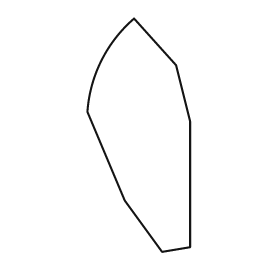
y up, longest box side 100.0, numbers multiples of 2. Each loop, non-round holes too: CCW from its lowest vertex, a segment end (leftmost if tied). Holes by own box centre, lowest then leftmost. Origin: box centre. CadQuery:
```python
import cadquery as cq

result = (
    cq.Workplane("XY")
    .moveTo(10.0, -50.0)
    .lineTo(22.0, -48.0)
    .lineTo(22.0, 6.0)
    .lineTo(16.0, 30.0)
    .lineTo(-2.0, 50.0)
    .threePointArc((-16.0, 32.0), (-22.0, 10.0))
    .lineTo(-6.0, -28.0)
    .close()
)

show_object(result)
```